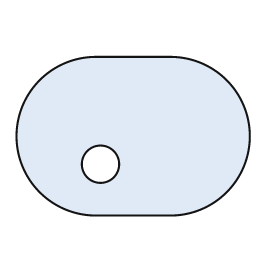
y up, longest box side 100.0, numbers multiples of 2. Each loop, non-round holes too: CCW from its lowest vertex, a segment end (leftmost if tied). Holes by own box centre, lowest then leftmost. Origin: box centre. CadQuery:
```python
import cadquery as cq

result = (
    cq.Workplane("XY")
    .moveTo(-16.0, -34.0)
    .lineTo(16.0, -34.0)
    .threePointArc((50.0, 0.0), (16.0, 34.0))
    .lineTo(-16.0, 34.0)
    .threePointArc((-50.0, 0.0), (-16.0, -34.0))
    .close()
    .moveTo(-14.0, -12.0)
    .circle(8.0)
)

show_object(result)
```